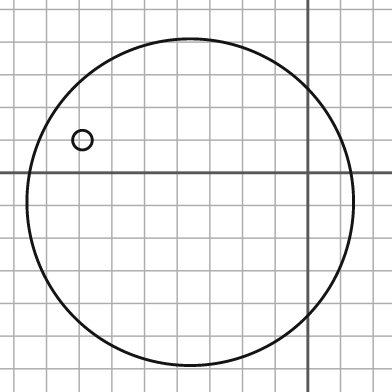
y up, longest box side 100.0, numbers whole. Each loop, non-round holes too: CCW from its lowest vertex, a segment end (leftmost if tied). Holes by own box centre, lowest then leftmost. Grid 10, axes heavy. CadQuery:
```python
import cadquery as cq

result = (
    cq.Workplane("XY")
    .moveTo(-36.0, -9.0)
    .circle(50.0)
    .moveTo(-69.0, 10.0)
    .circle(3.0)
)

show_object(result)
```